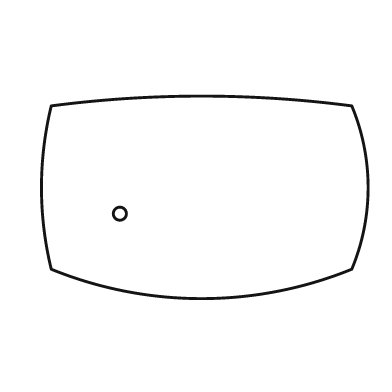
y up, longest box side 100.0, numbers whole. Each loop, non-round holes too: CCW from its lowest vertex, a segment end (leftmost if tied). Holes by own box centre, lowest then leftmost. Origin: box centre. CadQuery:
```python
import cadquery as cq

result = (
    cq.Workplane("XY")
    .moveTo(-47.0, -22.0)
    .threePointArc((-1.0, -31.0), (45.0, -22.0))
    .threePointArc((50.0, 3.0), (45.0, 28.0))
    .threePointArc((-1.0, 31.0), (-47.0, 28.0))
    .threePointArc((-50.0, 3.0), (-47.0, -22.0))
    .close()
    .moveTo(-26.0, -5.0)
    .circle(2.0)
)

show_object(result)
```